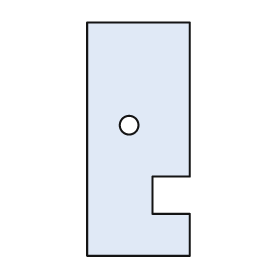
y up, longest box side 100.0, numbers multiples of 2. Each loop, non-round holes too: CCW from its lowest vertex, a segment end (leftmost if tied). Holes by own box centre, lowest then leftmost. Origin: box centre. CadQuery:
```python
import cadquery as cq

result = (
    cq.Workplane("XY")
    .moveTo(-22.0, -50.0)
    .lineTo(22.0, -50.0)
    .lineTo(22.0, -32.0)
    .lineTo(6.0, -32.0)
    .lineTo(6.0, -16.0)
    .lineTo(22.0, -16.0)
    .lineTo(22.0, 50.0)
    .lineTo(-22.0, 50.0)
    .close()
    .moveTo(-4.0, 6.0)
    .circle(4.0)
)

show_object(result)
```